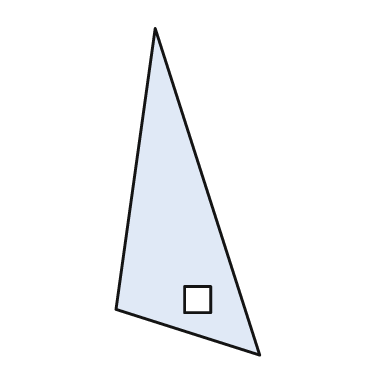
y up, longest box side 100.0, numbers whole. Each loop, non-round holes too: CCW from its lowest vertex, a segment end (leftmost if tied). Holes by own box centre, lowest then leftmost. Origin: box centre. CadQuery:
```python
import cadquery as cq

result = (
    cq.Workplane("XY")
    .moveTo(22.0, -50.0)
    .lineTo(-10.0, 50.0)
    .lineTo(-22.0, -36.0)
    .close()
    .moveTo(-1.0, -37.0)
    .lineTo(7.0, -37.0)
    .lineTo(7.0, -29.0)
    .lineTo(-1.0, -29.0)
    .close()
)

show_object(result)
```